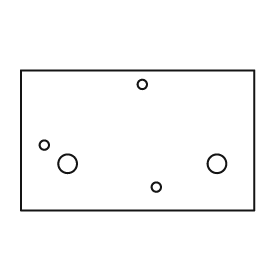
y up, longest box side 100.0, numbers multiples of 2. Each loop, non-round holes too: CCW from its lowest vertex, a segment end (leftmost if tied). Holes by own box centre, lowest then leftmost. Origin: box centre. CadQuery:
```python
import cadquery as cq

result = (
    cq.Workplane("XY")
    .moveTo(-50.0, -30.0)
    .lineTo(50.0, -30.0)
    .lineTo(50.0, 30.0)
    .lineTo(-50.0, 30.0)
    .close()
    .moveTo(8.0, -20.0)
    .circle(2.0)
    .moveTo(-30.0, -10.0)
    .circle(4.0)
    .moveTo(34.0, -10.0)
    .circle(4.0)
    .moveTo(-40.0, -2.0)
    .circle(2.0)
    .moveTo(2.0, 24.0)
    .circle(2.0)
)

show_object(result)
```